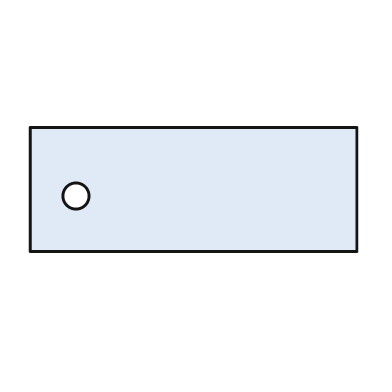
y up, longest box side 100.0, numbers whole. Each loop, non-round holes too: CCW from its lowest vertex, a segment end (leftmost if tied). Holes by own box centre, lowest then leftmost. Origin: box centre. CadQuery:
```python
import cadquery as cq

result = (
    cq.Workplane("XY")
    .moveTo(-50.0, -19.0)
    .lineTo(50.0, -19.0)
    .lineTo(50.0, 19.0)
    .lineTo(-50.0, 19.0)
    .close()
    .moveTo(-36.0, -2.0)
    .circle(4.0)
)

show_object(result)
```